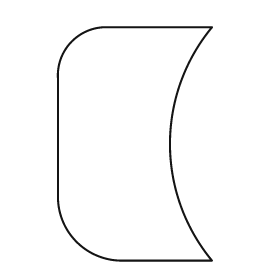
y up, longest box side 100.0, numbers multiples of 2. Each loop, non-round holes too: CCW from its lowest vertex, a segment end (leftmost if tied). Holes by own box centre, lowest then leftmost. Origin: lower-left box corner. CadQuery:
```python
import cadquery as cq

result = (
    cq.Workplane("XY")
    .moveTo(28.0, 0.0)
    .lineTo(66.0, 0.0)
    .threePointArc((48.0, 50.0), (66.0, 100.0))
    .lineTo(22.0, 100.0)
    .threePointArc((6.0, 94.0), (0.0, 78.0))
    .lineTo(0.0, 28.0)
    .threePointArc((8.0, 8.0), (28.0, 0.0))
    .close()
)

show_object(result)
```